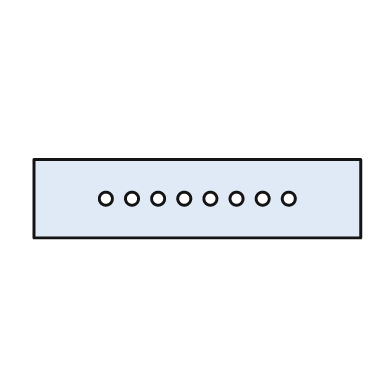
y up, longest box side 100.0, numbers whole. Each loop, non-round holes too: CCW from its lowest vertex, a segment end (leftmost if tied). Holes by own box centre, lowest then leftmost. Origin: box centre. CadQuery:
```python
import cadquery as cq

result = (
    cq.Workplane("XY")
    .moveTo(-50.0, -12.0)
    .lineTo(50.0, -12.0)
    .lineTo(50.0, 12.0)
    .lineTo(-50.0, 12.0)
    .close()
    .moveTo(-28.0, 0.0)
    .circle(2.0)
    .moveTo(-20.0, 0.0)
    .circle(2.0)
    .moveTo(-12.0, 0.0)
    .circle(2.0)
    .moveTo(-4.0, 0.0)
    .circle(2.0)
    .moveTo(4.0, 0.0)
    .circle(2.0)
    .moveTo(12.0, 0.0)
    .circle(2.0)
    .moveTo(20.0, 0.0)
    .circle(2.0)
    .moveTo(28.0, 0.0)
    .circle(2.0)
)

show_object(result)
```